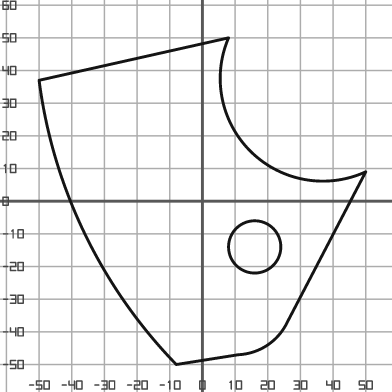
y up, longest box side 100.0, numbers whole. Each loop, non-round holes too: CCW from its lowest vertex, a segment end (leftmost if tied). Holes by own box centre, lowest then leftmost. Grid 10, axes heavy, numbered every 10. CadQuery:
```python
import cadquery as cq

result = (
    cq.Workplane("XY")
    .moveTo(-8.0, -50.0)
    .lineTo(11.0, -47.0)
    .threePointArc((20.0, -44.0), (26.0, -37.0))
    .lineTo(50.0, 9.0)
    .threePointArc((15.0, 15.0), (8.0, 50.0))
    .lineTo(-50.0, 37.0)
    .threePointArc((-36.0, -10.0), (-8.0, -50.0))
    .close()
    .moveTo(16.0, -14.0)
    .circle(8.0)
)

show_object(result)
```